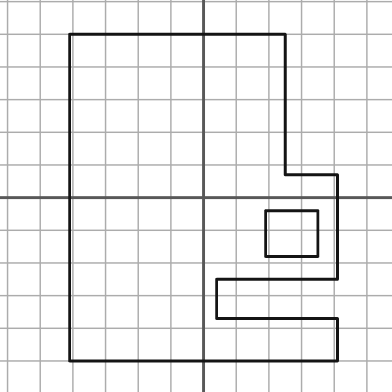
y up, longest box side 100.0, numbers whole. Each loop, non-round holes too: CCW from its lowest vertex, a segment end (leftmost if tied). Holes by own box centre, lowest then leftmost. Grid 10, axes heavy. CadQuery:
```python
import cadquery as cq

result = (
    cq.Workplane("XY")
    .moveTo(-41.0, -50.0)
    .lineTo(41.0, -50.0)
    .lineTo(41.0, -37.0)
    .lineTo(4.0, -37.0)
    .lineTo(4.0, -25.0)
    .lineTo(41.0, -25.0)
    .lineTo(41.0, 7.0)
    .lineTo(25.0, 7.0)
    .lineTo(25.0, 50.0)
    .lineTo(-41.0, 50.0)
    .close()
    .moveTo(19.0, -18.0)
    .lineTo(35.0, -18.0)
    .lineTo(35.0, -4.0)
    .lineTo(19.0, -4.0)
    .close()
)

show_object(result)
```